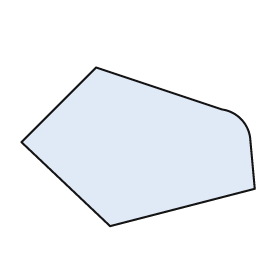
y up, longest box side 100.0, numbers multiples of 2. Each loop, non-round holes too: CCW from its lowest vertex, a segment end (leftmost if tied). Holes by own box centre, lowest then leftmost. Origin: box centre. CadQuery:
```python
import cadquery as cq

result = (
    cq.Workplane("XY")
    .moveTo(-12.0, -34.0)
    .lineTo(50.0, -18.0)
    .lineTo(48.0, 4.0)
    .threePointArc((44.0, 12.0), (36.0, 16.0))
    .lineTo(-18.0, 34.0)
    .lineTo(-50.0, 2.0)
    .close()
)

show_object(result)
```